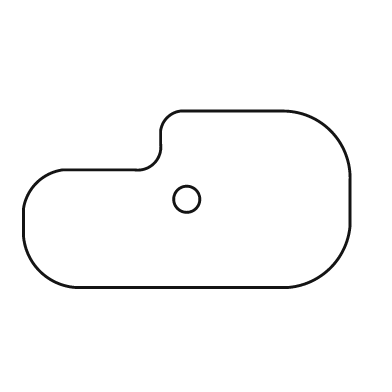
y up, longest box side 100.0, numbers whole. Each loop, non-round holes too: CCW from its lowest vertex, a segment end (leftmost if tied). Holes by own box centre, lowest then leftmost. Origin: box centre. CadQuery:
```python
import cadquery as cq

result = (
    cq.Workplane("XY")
    .moveTo(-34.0, -27.0)
    .lineTo(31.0, -27.0)
    .threePointArc((44.0, -21.0), (50.0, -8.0))
    .lineTo(50.0, 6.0)
    .threePointArc((44.0, 21.0), (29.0, 27.0))
    .lineTo(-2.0, 27.0)
    .threePointArc((-6.0, 25.0), (-8.0, 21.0))
    .lineTo(-8.0, 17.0)
    .threePointArc((-10.0, 11.0), (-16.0, 9.0))
    .lineTo(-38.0, 9.0)
    .threePointArc((-46.0, 5.0), (-50.0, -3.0))
    .lineTo(-50.0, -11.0)
    .threePointArc((-45.0, -22.0), (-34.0, -27.0))
    .close()
    .moveTo(0.0, 0.0)
    .circle(4.0)
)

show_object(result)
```